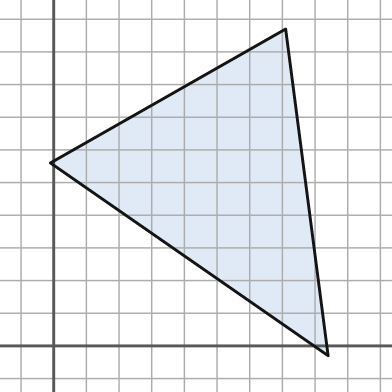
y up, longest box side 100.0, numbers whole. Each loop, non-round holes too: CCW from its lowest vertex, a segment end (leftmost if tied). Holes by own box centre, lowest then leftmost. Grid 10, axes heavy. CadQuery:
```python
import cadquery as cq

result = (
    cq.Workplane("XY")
    .moveTo(84.0, -3.0)
    .lineTo(71.0, 97.0)
    .lineTo(-1.0, 56.0)
    .close()
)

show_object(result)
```